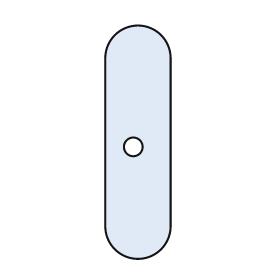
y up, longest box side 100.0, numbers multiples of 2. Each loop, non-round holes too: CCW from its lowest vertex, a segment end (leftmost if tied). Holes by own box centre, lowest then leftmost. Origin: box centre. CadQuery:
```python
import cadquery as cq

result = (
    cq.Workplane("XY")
    .moveTo(-14.0, -36.0)
    .threePointArc((0.0, -50.0), (14.0, -36.0))
    .lineTo(14.0, 36.0)
    .threePointArc((0.0, 50.0), (-14.0, 36.0))
    .close()
    .moveTo(-2.0, -2.0)
    .circle(4.0)
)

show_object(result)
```